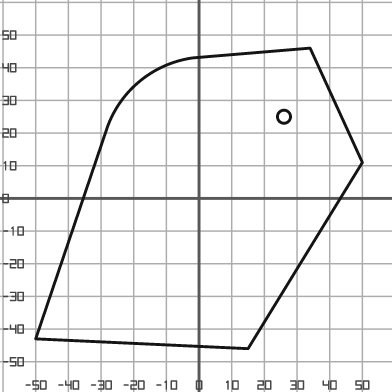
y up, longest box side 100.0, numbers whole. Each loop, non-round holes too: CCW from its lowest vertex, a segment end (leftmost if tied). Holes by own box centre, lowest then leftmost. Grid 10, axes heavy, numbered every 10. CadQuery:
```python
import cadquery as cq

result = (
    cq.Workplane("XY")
    .moveTo(15.0, -46.0)
    .lineTo(50.0, 11.0)
    .lineTo(34.0, 46.0)
    .lineTo(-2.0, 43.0)
    .threePointArc((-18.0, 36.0), (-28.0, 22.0))
    .lineTo(-50.0, -43.0)
    .close()
    .moveTo(26.0, 25.0)
    .circle(2.0)
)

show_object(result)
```